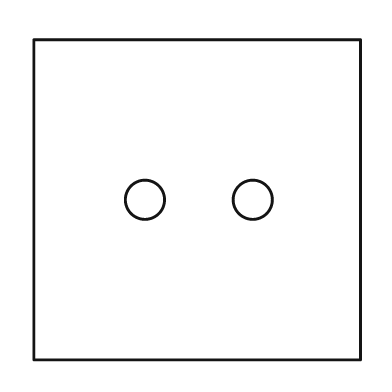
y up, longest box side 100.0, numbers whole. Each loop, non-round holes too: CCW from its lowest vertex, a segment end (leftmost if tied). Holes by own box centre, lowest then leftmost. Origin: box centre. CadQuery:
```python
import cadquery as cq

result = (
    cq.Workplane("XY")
    .moveTo(-50.0, -49.0)
    .lineTo(50.0, -49.0)
    .lineTo(50.0, 49.0)
    .lineTo(-50.0, 49.0)
    .close()
    .moveTo(-16.0, 0.0)
    .circle(6.0)
    .moveTo(17.0, 0.0)
    .circle(6.0)
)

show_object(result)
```